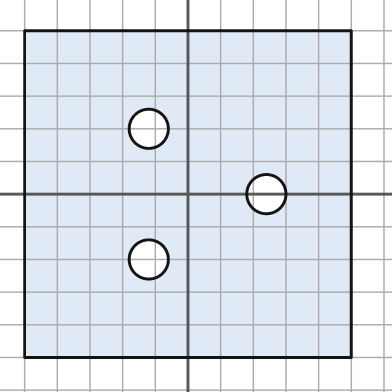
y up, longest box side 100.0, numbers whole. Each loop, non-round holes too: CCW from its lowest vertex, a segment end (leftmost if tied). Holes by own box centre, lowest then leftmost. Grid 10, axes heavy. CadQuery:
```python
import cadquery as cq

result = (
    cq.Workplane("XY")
    .moveTo(-50.0, -50.0)
    .lineTo(50.0, -50.0)
    .lineTo(50.0, 50.0)
    .lineTo(-50.0, 50.0)
    .close()
    .moveTo(-12.0, -20.0)
    .circle(6.0)
    .moveTo(24.0, 0.0)
    .circle(6.0)
    .moveTo(-12.0, 20.0)
    .circle(6.0)
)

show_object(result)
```